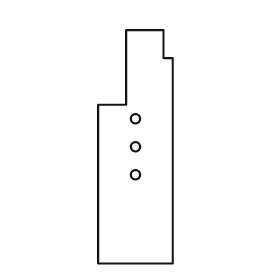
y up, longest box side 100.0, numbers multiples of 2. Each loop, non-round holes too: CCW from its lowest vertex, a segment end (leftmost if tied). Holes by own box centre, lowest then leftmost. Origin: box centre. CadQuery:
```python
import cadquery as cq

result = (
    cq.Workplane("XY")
    .moveTo(-16.0, -50.0)
    .lineTo(16.0, -50.0)
    .lineTo(16.0, 38.0)
    .lineTo(12.0, 38.0)
    .lineTo(12.0, 50.0)
    .lineTo(-4.0, 50.0)
    .lineTo(-4.0, 18.0)
    .lineTo(-16.0, 18.0)
    .close()
    .moveTo(0.0, -12.0)
    .circle(2.0)
    .moveTo(0.0, 0.0)
    .circle(2.0)
    .moveTo(0.0, 12.0)
    .circle(2.0)
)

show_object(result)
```